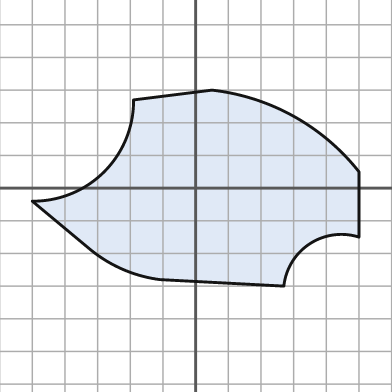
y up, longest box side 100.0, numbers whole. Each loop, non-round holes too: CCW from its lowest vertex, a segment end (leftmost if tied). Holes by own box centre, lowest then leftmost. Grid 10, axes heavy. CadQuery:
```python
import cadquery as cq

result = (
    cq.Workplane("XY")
    .moveTo(27.0, -30.0)
    .threePointArc((35.0, -17.0), (50.0, -15.0))
    .lineTo(50.0, 5.0)
    .threePointArc((30.0, 22.0), (5.0, 30.0))
    .lineTo(-19.0, 27.0)
    .threePointArc((-28.0, 5.0), (-50.0, -4.0))
    .lineTo(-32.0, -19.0)
    .threePointArc((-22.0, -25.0), (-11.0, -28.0))
    .close()
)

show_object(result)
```